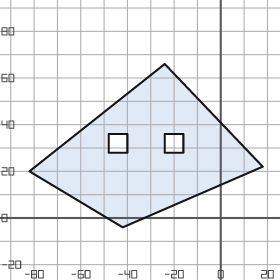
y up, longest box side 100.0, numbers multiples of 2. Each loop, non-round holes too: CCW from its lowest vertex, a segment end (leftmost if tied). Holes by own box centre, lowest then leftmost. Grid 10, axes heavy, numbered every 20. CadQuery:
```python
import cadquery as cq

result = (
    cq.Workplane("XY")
    .moveTo(-42.0, -4.0)
    .lineTo(18.0, 22.0)
    .lineTo(-24.0, 66.0)
    .lineTo(-82.0, 20.0)
    .close()
    .moveTo(-48.0, 28.0)
    .lineTo(-40.0, 28.0)
    .lineTo(-40.0, 36.0)
    .lineTo(-48.0, 36.0)
    .close()
    .moveTo(-24.0, 28.0)
    .lineTo(-16.0, 28.0)
    .lineTo(-16.0, 36.0)
    .lineTo(-24.0, 36.0)
    .close()
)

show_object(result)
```